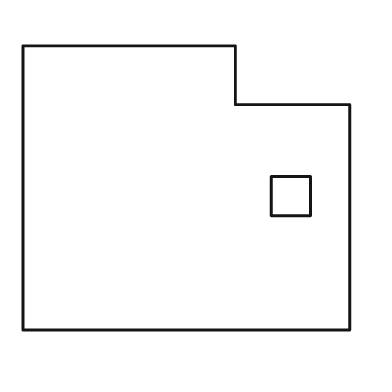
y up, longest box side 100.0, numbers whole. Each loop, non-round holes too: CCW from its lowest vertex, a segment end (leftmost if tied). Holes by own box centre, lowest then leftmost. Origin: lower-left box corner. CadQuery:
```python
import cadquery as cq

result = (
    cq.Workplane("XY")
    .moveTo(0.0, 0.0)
    .lineTo(100.0, 0.0)
    .lineTo(100.0, 69.0)
    .lineTo(65.0, 69.0)
    .lineTo(65.0, 87.0)
    .lineTo(0.0, 87.0)
    .close()
    .moveTo(76.0, 35.0)
    .lineTo(88.0, 35.0)
    .lineTo(88.0, 47.0)
    .lineTo(76.0, 47.0)
    .close()
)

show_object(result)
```